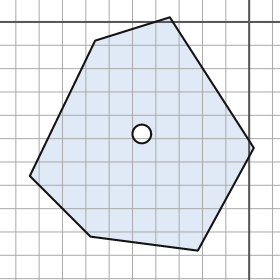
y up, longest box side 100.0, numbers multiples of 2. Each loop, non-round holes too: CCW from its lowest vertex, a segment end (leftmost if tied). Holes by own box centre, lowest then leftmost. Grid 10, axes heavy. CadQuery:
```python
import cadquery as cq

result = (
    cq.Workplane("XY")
    .moveTo(-22.0, -98.0)
    .lineTo(2.0, -54.0)
    .lineTo(-34.0, 2.0)
    .lineTo(-66.0, -8.0)
    .lineTo(-94.0, -66.0)
    .lineTo(-68.0, -92.0)
    .close()
    .moveTo(-46.0, -48.0)
    .circle(4.0)
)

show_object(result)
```